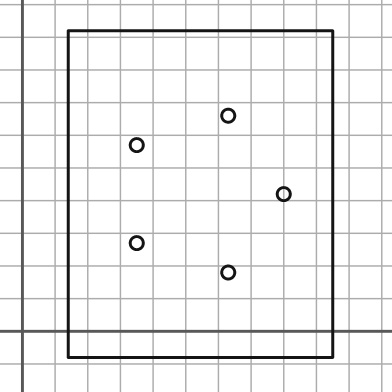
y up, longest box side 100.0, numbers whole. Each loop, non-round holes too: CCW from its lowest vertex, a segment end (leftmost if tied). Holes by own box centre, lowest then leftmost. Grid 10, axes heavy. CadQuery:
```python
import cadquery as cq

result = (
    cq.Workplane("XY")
    .moveTo(14.0, -8.0)
    .lineTo(95.0, -8.0)
    .lineTo(95.0, 92.0)
    .lineTo(14.0, 92.0)
    .close()
    .moveTo(63.0, 18.0)
    .circle(2.0)
    .moveTo(35.0, 27.0)
    .circle(2.0)
    .moveTo(80.0, 42.0)
    .circle(2.0)
    .moveTo(35.0, 57.0)
    .circle(2.0)
    .moveTo(63.0, 66.0)
    .circle(2.0)
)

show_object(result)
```